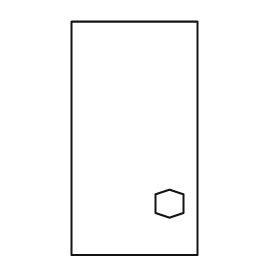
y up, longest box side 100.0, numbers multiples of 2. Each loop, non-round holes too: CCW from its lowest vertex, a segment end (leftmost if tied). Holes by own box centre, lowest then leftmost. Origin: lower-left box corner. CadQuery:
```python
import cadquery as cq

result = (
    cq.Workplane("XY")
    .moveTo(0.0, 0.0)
    .lineTo(54.0, 0.0)
    .lineTo(54.0, 100.0)
    .lineTo(0.0, 100.0)
    .close()
    .moveTo(42.0, 16.0)
    .lineTo(48.0, 18.0)
    .lineTo(48.0, 26.0)
    .lineTo(42.0, 28.0)
    .lineTo(36.0, 26.0)
    .lineTo(36.0, 18.0)
    .close()
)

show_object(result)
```